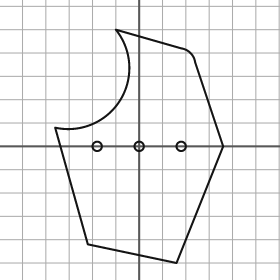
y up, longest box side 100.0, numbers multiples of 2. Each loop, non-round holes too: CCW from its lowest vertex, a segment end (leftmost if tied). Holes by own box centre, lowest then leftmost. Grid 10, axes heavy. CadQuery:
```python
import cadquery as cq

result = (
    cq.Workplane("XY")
    .moveTo(16.0, -50.0)
    .lineTo(36.0, 0.0)
    .lineTo(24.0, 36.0)
    .threePointArc((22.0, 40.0), (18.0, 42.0))
    .lineTo(-10.0, 50.0)
    .threePointArc((-8.0, 20.0), (-36.0, 8.0))
    .lineTo(-22.0, -42.0)
    .close()
    .moveTo(-18.0, 0.0)
    .circle(2.0)
    .moveTo(0.0, 0.0)
    .circle(2.0)
    .moveTo(18.0, 0.0)
    .circle(2.0)
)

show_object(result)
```